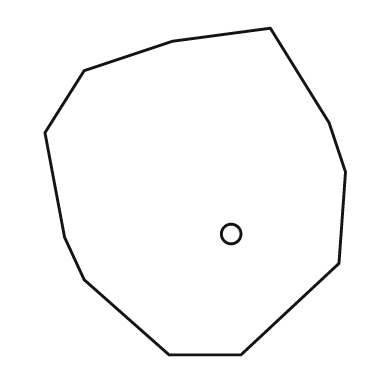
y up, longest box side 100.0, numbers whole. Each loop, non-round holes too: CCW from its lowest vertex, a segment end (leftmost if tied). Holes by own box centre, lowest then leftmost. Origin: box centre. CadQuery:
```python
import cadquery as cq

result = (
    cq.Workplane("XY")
    .moveTo(-8.0, -50.0)
    .lineTo(14.0, -50.0)
    .lineTo(44.0, -22.0)
    .lineTo(46.0, 6.0)
    .lineTo(41.0, 21.0)
    .lineTo(23.0, 50.0)
    .lineTo(-7.0, 46.0)
    .lineTo(-34.0, 37.0)
    .lineTo(-46.0, 18.0)
    .lineTo(-40.0, -14.0)
    .lineTo(-34.0, -27.0)
    .close()
    .moveTo(11.0, -13.0)
    .circle(3.0)
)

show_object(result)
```